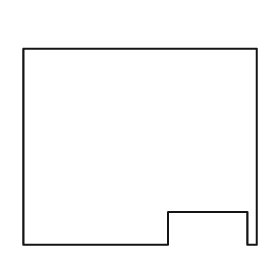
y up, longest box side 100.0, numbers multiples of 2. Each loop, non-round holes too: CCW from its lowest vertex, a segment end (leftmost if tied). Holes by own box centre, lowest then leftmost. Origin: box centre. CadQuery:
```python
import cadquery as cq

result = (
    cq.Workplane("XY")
    .moveTo(-50.0, -42.0)
    .lineTo(12.0, -42.0)
    .lineTo(12.0, -28.0)
    .lineTo(46.0, -28.0)
    .lineTo(46.0, -42.0)
    .lineTo(50.0, -42.0)
    .lineTo(50.0, 42.0)
    .lineTo(-50.0, 42.0)
    .close()
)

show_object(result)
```